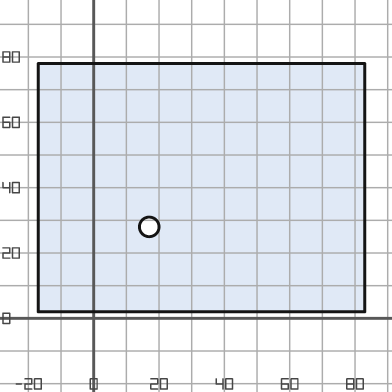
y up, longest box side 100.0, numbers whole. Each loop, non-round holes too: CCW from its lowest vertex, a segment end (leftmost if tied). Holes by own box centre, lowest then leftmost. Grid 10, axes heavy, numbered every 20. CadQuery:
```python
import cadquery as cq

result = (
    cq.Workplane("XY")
    .moveTo(-17.0, 2.0)
    .lineTo(83.0, 2.0)
    .lineTo(83.0, 78.0)
    .lineTo(-17.0, 78.0)
    .close()
    .moveTo(17.0, 28.0)
    .circle(3.0)
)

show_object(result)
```